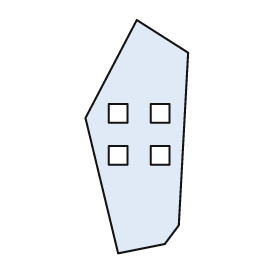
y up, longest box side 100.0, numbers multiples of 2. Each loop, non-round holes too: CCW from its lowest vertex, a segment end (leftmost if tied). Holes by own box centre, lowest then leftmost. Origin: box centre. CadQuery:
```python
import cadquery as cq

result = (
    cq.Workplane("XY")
    .moveTo(-8.0, -50.0)
    .lineTo(12.0, -46.0)
    .lineTo(18.0, -38.0)
    .lineTo(22.0, 36.0)
    .lineTo(0.0, 50.0)
    .lineTo(-22.0, 8.0)
    .close()
    .moveTo(-12.0, -12.0)
    .lineTo(-4.0, -12.0)
    .lineTo(-4.0, -4.0)
    .lineTo(-12.0, -4.0)
    .close()
    .moveTo(6.0, -12.0)
    .lineTo(14.0, -12.0)
    .lineTo(14.0, -4.0)
    .lineTo(6.0, -4.0)
    .close()
    .moveTo(-12.0, 6.0)
    .lineTo(-4.0, 6.0)
    .lineTo(-4.0, 14.0)
    .lineTo(-12.0, 14.0)
    .close()
    .moveTo(6.0, 6.0)
    .lineTo(14.0, 6.0)
    .lineTo(14.0, 14.0)
    .lineTo(6.0, 14.0)
    .close()
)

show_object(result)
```